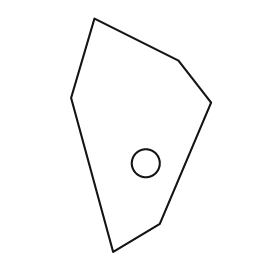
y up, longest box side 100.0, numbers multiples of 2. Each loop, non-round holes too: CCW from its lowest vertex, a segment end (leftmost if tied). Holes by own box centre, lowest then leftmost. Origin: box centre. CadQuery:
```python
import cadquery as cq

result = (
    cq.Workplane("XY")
    .moveTo(-12.0, -50.0)
    .lineTo(8.0, -38.0)
    .lineTo(30.0, 14.0)
    .lineTo(16.0, 32.0)
    .lineTo(-20.0, 50.0)
    .lineTo(-30.0, 16.0)
    .close()
    .moveTo(2.0, -12.0)
    .circle(6.0)
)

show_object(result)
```